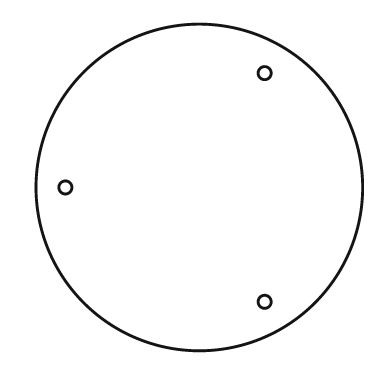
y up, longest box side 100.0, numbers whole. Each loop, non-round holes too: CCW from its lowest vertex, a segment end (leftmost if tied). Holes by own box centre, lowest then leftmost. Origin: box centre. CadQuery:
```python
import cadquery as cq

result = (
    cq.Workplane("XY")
    .moveTo(0.0, 0.0)
    .circle(50.0)
    .moveTo(20.0, -35.0)
    .circle(2.0)
    .moveTo(-41.0, 0.0)
    .circle(2.0)
    .moveTo(20.0, 35.0)
    .circle(2.0)
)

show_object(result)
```